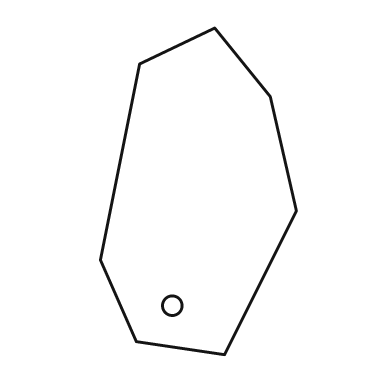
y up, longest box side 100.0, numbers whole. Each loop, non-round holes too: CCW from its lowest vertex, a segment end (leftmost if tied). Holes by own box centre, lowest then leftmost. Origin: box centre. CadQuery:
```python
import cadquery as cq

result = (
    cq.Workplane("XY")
    .moveTo(8.0, -50.0)
    .lineTo(30.0, -6.0)
    .lineTo(22.0, 29.0)
    .lineTo(5.0, 50.0)
    .lineTo(-18.0, 39.0)
    .lineTo(-30.0, -21.0)
    .lineTo(-19.0, -46.0)
    .close()
    .moveTo(-8.0, -35.0)
    .circle(3.0)
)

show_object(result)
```